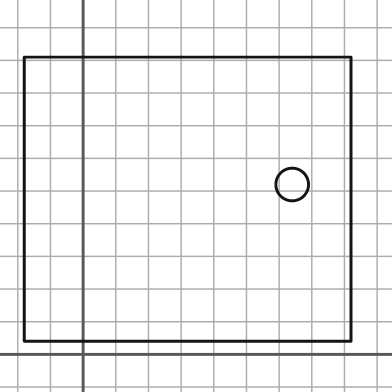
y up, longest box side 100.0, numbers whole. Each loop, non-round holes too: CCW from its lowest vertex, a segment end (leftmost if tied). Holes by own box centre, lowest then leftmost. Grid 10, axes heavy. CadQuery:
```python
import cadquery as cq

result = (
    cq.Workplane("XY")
    .moveTo(-18.0, 4.0)
    .lineTo(82.0, 4.0)
    .lineTo(82.0, 91.0)
    .lineTo(-18.0, 91.0)
    .close()
    .moveTo(64.0, 52.0)
    .circle(5.0)
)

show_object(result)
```